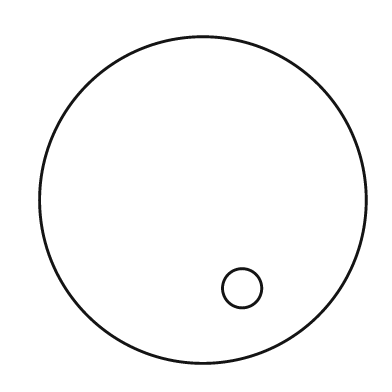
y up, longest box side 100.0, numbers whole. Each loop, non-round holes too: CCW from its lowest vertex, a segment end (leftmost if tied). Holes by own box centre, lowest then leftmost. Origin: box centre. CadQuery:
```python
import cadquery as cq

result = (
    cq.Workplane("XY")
    .moveTo(0.0, 0.0)
    .circle(50.0)
    .moveTo(12.0, -27.0)
    .circle(6.0)
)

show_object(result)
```